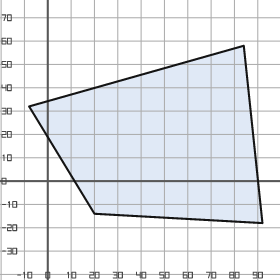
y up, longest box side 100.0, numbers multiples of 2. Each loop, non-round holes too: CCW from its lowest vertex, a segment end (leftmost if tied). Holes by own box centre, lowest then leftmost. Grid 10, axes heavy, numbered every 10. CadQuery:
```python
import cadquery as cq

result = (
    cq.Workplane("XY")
    .moveTo(92.0, -18.0)
    .lineTo(84.0, 58.0)
    .lineTo(-8.0, 32.0)
    .lineTo(20.0, -14.0)
    .close()
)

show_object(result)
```